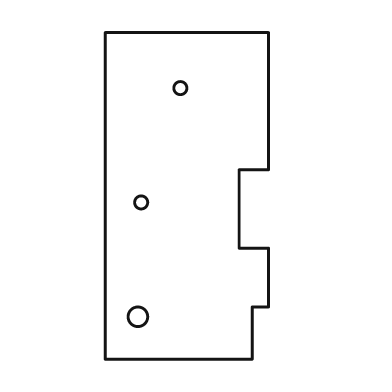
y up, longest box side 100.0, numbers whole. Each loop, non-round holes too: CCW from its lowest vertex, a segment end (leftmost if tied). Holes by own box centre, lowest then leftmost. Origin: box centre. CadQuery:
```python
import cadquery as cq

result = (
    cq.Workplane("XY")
    .moveTo(-25.0, -50.0)
    .lineTo(20.0, -50.0)
    .lineTo(20.0, -34.0)
    .lineTo(25.0, -34.0)
    .lineTo(25.0, -16.0)
    .lineTo(16.0, -16.0)
    .lineTo(16.0, 8.0)
    .lineTo(25.0, 8.0)
    .lineTo(25.0, 50.0)
    .lineTo(-25.0, 50.0)
    .close()
    .moveTo(-15.0, -37.0)
    .circle(3.0)
    .moveTo(-14.0, -2.0)
    .circle(2.0)
    .moveTo(-2.0, 33.0)
    .circle(2.0)
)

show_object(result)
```